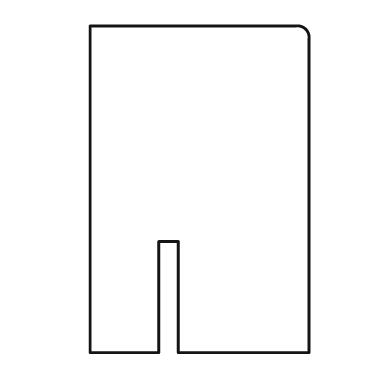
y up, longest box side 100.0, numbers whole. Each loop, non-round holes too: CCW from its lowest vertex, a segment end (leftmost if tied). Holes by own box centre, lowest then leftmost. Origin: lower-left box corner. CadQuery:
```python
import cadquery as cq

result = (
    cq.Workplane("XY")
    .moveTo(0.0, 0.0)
    .lineTo(21.0, 0.0)
    .lineTo(21.0, 34.0)
    .lineTo(27.0, 34.0)
    .lineTo(27.0, 0.0)
    .lineTo(67.0, 0.0)
    .lineTo(67.0, 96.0)
    .threePointArc((66.0, 99.0), (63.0, 100.0))
    .lineTo(0.0, 100.0)
    .close()
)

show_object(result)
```